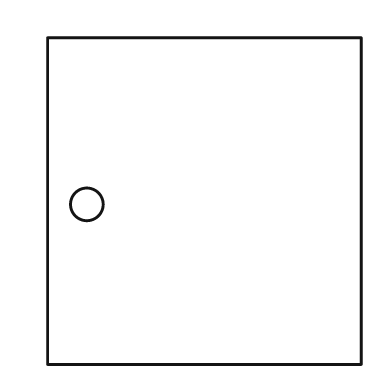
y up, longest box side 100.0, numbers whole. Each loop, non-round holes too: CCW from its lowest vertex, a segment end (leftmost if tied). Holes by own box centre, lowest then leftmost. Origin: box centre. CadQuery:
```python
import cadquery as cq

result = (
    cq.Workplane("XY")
    .moveTo(-48.0, -50.0)
    .lineTo(48.0, -50.0)
    .lineTo(48.0, 50.0)
    .lineTo(-48.0, 50.0)
    .close()
    .moveTo(-36.0, -1.0)
    .circle(5.0)
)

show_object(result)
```